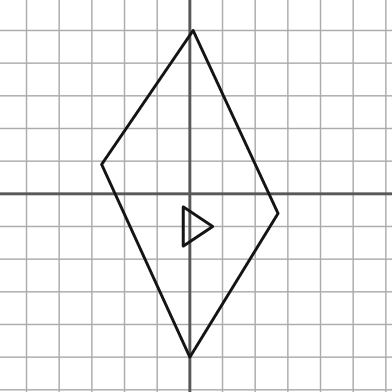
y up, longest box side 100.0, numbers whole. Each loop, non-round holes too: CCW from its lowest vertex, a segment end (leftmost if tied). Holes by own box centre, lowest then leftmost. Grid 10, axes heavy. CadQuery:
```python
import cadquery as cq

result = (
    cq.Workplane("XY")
    .moveTo(0.0, -50.0)
    .lineTo(27.0, -6.0)
    .lineTo(1.0, 50.0)
    .lineTo(-27.0, 9.0)
    .close()
    .moveTo(-2.0, -16.0)
    .lineTo(7.0, -10.0)
    .lineTo(-2.0, -4.0)
    .close()
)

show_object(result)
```